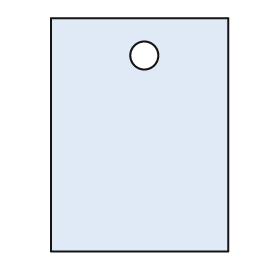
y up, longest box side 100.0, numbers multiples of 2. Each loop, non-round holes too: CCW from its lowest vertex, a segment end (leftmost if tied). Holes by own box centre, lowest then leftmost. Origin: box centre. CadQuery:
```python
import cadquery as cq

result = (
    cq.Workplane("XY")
    .moveTo(-38.0, -50.0)
    .lineTo(38.0, -50.0)
    .lineTo(38.0, 50.0)
    .lineTo(-38.0, 50.0)
    .close()
    .moveTo(2.0, 34.0)
    .circle(6.0)
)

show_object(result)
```